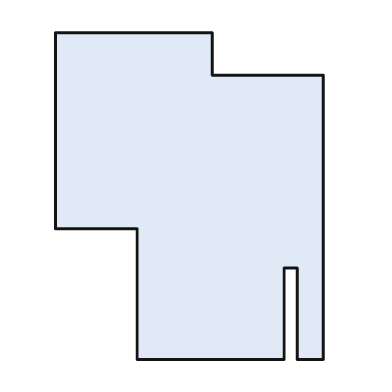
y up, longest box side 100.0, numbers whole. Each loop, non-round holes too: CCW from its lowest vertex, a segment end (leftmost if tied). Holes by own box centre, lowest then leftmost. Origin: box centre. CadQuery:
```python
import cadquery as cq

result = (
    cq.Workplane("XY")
    .moveTo(-16.0, -50.0)
    .lineTo(29.0, -50.0)
    .lineTo(29.0, -22.0)
    .lineTo(33.0, -22.0)
    .lineTo(33.0, -50.0)
    .lineTo(41.0, -50.0)
    .lineTo(41.0, 37.0)
    .lineTo(7.0, 37.0)
    .lineTo(7.0, 50.0)
    .lineTo(-41.0, 50.0)
    .lineTo(-41.0, -10.0)
    .lineTo(-16.0, -10.0)
    .close()
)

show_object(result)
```